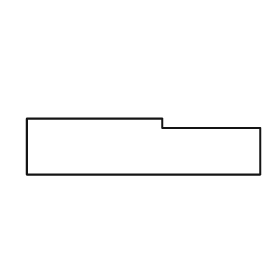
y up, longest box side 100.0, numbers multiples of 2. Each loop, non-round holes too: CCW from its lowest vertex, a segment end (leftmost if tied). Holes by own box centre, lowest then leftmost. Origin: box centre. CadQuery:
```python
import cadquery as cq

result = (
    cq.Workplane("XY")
    .moveTo(-50.0, -12.0)
    .lineTo(50.0, -12.0)
    .lineTo(50.0, 8.0)
    .lineTo(8.0, 8.0)
    .lineTo(8.0, 12.0)
    .lineTo(-50.0, 12.0)
    .close()
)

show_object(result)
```